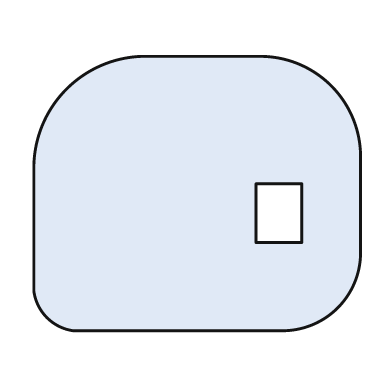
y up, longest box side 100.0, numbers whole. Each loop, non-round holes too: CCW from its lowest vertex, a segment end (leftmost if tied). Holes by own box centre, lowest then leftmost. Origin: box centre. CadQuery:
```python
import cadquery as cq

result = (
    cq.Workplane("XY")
    .moveTo(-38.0, -42.0)
    .lineTo(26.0, -42.0)
    .threePointArc((43.0, -35.0), (50.0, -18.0))
    .lineTo(50.0, 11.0)
    .threePointArc((41.0, 33.0), (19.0, 42.0))
    .lineTo(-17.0, 42.0)
    .threePointArc((-40.0, 32.0), (-50.0, 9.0))
    .lineTo(-50.0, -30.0)
    .threePointArc((-46.0, -38.0), (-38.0, -42.0))
    .close()
    .moveTo(18.0, -15.0)
    .lineTo(32.0, -15.0)
    .lineTo(32.0, 3.0)
    .lineTo(18.0, 3.0)
    .close()
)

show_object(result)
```